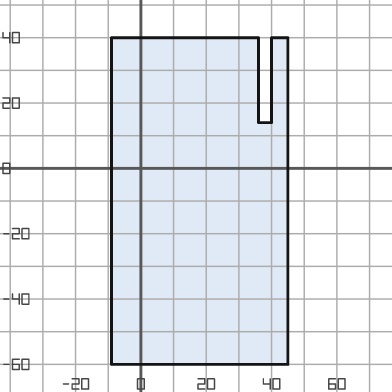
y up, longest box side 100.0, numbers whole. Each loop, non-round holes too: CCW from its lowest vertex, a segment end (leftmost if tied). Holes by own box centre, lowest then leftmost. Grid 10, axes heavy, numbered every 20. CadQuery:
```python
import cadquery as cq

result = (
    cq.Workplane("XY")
    .moveTo(-9.0, -60.0)
    .lineTo(45.0, -60.0)
    .lineTo(45.0, 40.0)
    .lineTo(40.0, 40.0)
    .lineTo(40.0, 14.0)
    .lineTo(36.0, 14.0)
    .lineTo(36.0, 40.0)
    .lineTo(-9.0, 40.0)
    .close()
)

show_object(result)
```